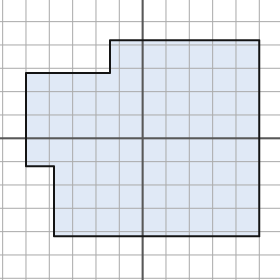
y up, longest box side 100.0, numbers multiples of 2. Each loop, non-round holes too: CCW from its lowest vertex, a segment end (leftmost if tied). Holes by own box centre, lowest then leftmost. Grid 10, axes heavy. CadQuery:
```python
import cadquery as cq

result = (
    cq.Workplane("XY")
    .moveTo(-38.0, -42.0)
    .lineTo(50.0, -42.0)
    .lineTo(50.0, 42.0)
    .lineTo(-14.0, 42.0)
    .lineTo(-14.0, 28.0)
    .lineTo(-50.0, 28.0)
    .lineTo(-50.0, -12.0)
    .lineTo(-38.0, -12.0)
    .close()
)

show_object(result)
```